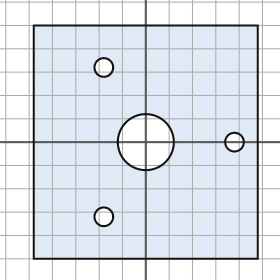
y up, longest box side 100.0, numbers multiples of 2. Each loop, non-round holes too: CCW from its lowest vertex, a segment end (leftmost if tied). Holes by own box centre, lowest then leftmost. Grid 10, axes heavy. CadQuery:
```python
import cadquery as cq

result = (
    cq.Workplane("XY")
    .moveTo(-48.0, -50.0)
    .lineTo(48.0, -50.0)
    .lineTo(48.0, 50.0)
    .lineTo(-48.0, 50.0)
    .close()
    .moveTo(-18.0, -32.0)
    .circle(4.0)
    .moveTo(0.0, 0.0)
    .circle(12.0)
    .moveTo(38.0, 0.0)
    .circle(4.0)
    .moveTo(-18.0, 32.0)
    .circle(4.0)
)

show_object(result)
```